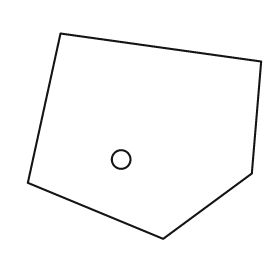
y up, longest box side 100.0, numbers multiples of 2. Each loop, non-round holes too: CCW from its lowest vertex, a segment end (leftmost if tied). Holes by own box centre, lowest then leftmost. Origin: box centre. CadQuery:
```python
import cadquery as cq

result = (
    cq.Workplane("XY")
    .moveTo(8.0, -44.0)
    .lineTo(46.0, -16.0)
    .lineTo(50.0, 32.0)
    .lineTo(-36.0, 44.0)
    .lineTo(-50.0, -20.0)
    .close()
    .moveTo(-10.0, -10.0)
    .circle(4.0)
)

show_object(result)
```